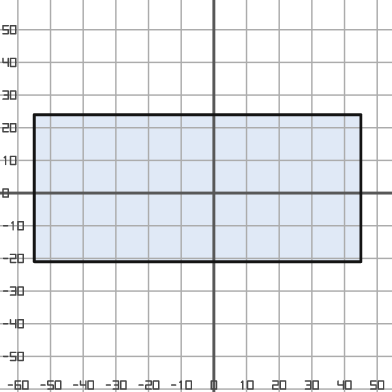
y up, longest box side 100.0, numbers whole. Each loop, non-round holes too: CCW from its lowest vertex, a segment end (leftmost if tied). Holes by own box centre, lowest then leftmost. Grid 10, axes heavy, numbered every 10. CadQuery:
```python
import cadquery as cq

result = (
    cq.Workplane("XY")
    .moveTo(-55.0, -21.0)
    .lineTo(45.0, -21.0)
    .lineTo(45.0, 24.0)
    .lineTo(-55.0, 24.0)
    .close()
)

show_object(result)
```